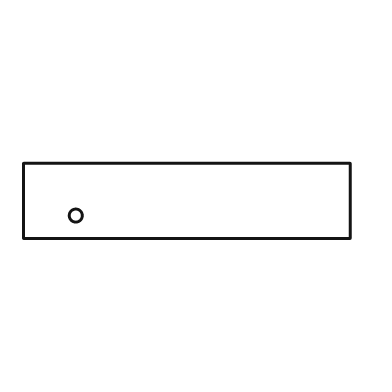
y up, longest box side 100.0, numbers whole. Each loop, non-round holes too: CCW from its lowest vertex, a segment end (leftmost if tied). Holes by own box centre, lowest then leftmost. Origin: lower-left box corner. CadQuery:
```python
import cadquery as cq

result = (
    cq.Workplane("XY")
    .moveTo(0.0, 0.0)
    .lineTo(100.0, 0.0)
    .lineTo(100.0, 23.0)
    .lineTo(0.0, 23.0)
    .close()
    .moveTo(16.0, 7.0)
    .circle(2.0)
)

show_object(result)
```